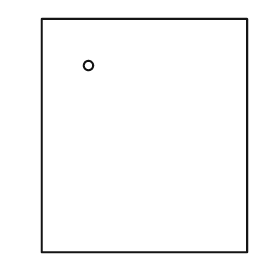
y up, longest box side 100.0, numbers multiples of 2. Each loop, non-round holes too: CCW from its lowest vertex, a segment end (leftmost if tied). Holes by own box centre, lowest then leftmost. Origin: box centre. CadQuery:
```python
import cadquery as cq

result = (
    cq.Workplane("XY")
    .moveTo(-44.0, -50.0)
    .lineTo(44.0, -50.0)
    .lineTo(44.0, 50.0)
    .lineTo(-44.0, 50.0)
    .close()
    .moveTo(-24.0, 30.0)
    .circle(2.0)
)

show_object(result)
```